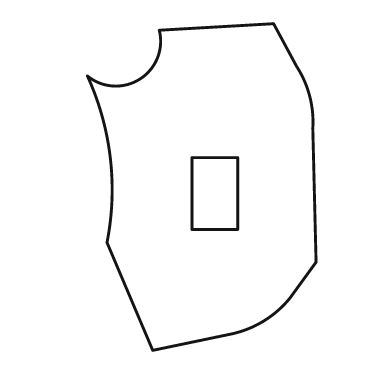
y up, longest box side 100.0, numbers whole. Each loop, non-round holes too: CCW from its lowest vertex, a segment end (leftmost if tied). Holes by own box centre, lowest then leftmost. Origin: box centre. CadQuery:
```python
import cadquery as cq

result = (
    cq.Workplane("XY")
    .moveTo(-15.0, -50.0)
    .lineTo(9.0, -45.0)
    .threePointArc((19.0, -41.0), (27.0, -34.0))
    .lineTo(35.0, -23.0)
    .lineTo(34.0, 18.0)
    .threePointArc((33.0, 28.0), (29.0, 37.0))
    .lineTo(22.0, 50.0)
    .lineTo(-13.0, 48.0)
    .threePointArc((-19.0, 33.0), (-35.0, 34.0))
    .threePointArc((-28.0, 9.0), (-29.0, -17.0))
    .close()
    .moveTo(-3.0, -13.0)
    .lineTo(11.0, -13.0)
    .lineTo(11.0, 9.0)
    .lineTo(-3.0, 9.0)
    .close()
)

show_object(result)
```